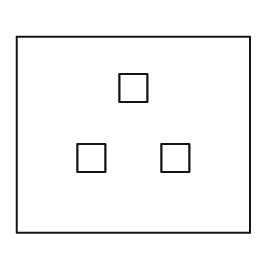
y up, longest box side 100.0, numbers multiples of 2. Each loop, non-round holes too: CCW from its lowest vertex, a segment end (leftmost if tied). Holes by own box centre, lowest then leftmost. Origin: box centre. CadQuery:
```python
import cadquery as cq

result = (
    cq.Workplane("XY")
    .moveTo(-50.0, -42.0)
    .lineTo(50.0, -42.0)
    .lineTo(50.0, 42.0)
    .lineTo(-50.0, 42.0)
    .close()
    .moveTo(-24.0, -16.0)
    .lineTo(-12.0, -16.0)
    .lineTo(-12.0, -4.0)
    .lineTo(-24.0, -4.0)
    .close()
    .moveTo(12.0, -16.0)
    .lineTo(24.0, -16.0)
    .lineTo(24.0, -4.0)
    .lineTo(12.0, -4.0)
    .close()
    .moveTo(-6.0, 14.0)
    .lineTo(6.0, 14.0)
    .lineTo(6.0, 26.0)
    .lineTo(-6.0, 26.0)
    .close()
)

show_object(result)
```